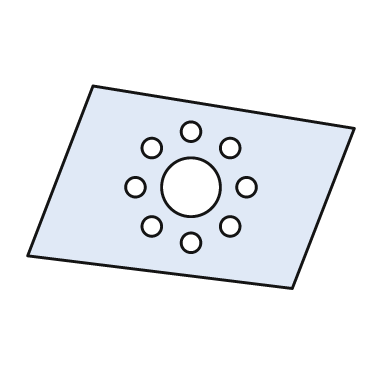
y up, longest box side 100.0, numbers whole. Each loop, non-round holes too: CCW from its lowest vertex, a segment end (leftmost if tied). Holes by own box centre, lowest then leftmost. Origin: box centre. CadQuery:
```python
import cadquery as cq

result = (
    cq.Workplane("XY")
    .moveTo(31.0, -31.0)
    .lineTo(50.0, 18.0)
    .lineTo(-30.0, 31.0)
    .lineTo(-50.0, -21.0)
    .close()
    .moveTo(0.0, -17.0)
    .circle(3.0)
    .moveTo(-12.0, -12.0)
    .circle(3.0)
    .moveTo(12.0, -12.0)
    .circle(3.0)
    .moveTo(-17.0, 0.0)
    .circle(3.0)
    .moveTo(0.0, 0.0)
    .circle(9.0)
    .moveTo(17.0, 0.0)
    .circle(3.0)
    .moveTo(-12.0, 12.0)
    .circle(3.0)
    .moveTo(12.0, 12.0)
    .circle(3.0)
    .moveTo(0.0, 17.0)
    .circle(3.0)
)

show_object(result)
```